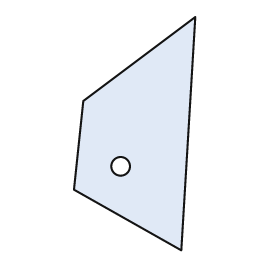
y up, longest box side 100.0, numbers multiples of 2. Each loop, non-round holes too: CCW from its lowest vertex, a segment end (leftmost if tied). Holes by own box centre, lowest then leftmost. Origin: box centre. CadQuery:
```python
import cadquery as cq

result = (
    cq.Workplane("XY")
    .moveTo(20.0, -50.0)
    .lineTo(26.0, 50.0)
    .lineTo(-22.0, 14.0)
    .lineTo(-26.0, -24.0)
    .close()
    .moveTo(-6.0, -14.0)
    .circle(4.0)
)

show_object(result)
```